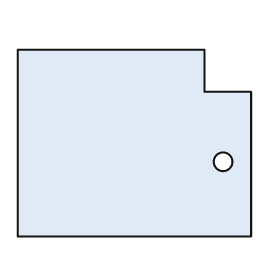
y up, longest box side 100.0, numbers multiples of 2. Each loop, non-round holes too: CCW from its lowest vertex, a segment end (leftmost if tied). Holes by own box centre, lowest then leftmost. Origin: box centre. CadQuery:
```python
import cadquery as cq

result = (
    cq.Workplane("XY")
    .moveTo(-50.0, -40.0)
    .lineTo(50.0, -40.0)
    .lineTo(50.0, 22.0)
    .lineTo(30.0, 22.0)
    .lineTo(30.0, 40.0)
    .lineTo(-50.0, 40.0)
    .close()
    .moveTo(38.0, -8.0)
    .circle(4.0)
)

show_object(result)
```